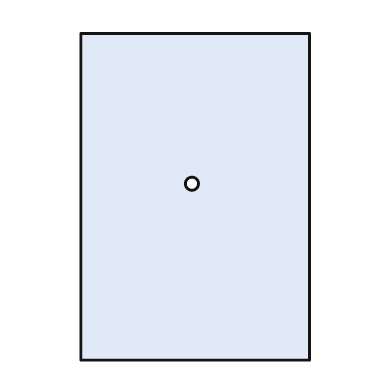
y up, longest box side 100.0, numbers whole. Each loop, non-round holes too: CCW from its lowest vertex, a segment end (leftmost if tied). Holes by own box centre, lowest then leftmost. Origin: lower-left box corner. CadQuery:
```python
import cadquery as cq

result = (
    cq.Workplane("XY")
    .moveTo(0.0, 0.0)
    .lineTo(70.0, 0.0)
    .lineTo(70.0, 100.0)
    .lineTo(0.0, 100.0)
    .close()
    .moveTo(34.0, 54.0)
    .circle(2.0)
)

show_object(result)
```